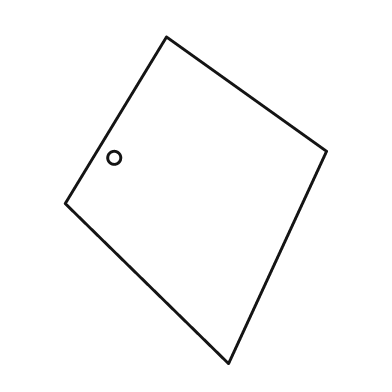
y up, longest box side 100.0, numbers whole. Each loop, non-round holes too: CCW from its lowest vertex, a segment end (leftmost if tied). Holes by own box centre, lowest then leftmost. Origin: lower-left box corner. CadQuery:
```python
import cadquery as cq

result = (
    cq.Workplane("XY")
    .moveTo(50.0, 0.0)
    .lineTo(80.0, 65.0)
    .lineTo(31.0, 100.0)
    .lineTo(0.0, 49.0)
    .close()
    .moveTo(15.0, 63.0)
    .circle(2.0)
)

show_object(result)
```